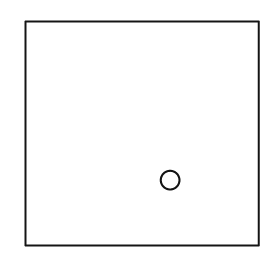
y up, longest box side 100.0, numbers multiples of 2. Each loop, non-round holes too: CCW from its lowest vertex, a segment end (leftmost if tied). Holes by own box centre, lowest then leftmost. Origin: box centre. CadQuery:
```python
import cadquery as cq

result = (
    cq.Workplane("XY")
    .moveTo(-50.0, -48.0)
    .lineTo(50.0, -48.0)
    .lineTo(50.0, 48.0)
    .lineTo(-50.0, 48.0)
    .close()
    .moveTo(12.0, -20.0)
    .circle(4.0)
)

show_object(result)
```